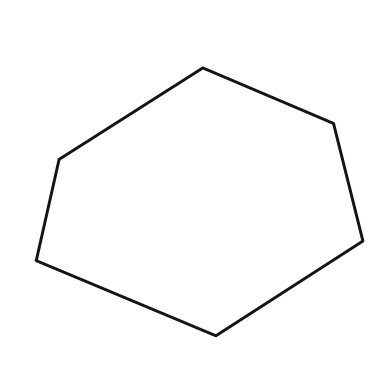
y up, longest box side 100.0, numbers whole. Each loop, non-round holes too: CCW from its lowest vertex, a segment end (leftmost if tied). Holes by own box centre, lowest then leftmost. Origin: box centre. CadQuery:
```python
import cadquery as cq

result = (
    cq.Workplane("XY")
    .moveTo(5.0, -41.0)
    .lineTo(50.0, -12.0)
    .lineTo(41.0, 24.0)
    .lineTo(1.0, 41.0)
    .lineTo(-43.0, 13.0)
    .lineTo(-50.0, -18.0)
    .close()
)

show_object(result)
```